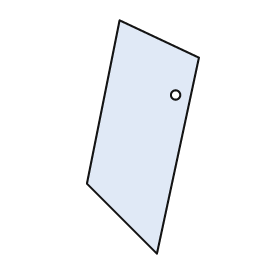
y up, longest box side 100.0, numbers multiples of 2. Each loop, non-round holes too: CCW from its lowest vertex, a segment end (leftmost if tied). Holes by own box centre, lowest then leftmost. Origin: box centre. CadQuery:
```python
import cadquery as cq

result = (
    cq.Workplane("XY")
    .moveTo(6.0, -50.0)
    .lineTo(24.0, 34.0)
    .lineTo(-10.0, 50.0)
    .lineTo(-24.0, -20.0)
    .close()
    .moveTo(14.0, 18.0)
    .circle(2.0)
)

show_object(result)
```